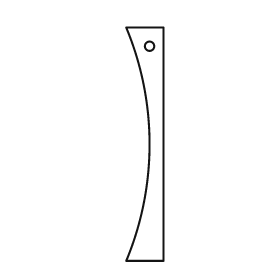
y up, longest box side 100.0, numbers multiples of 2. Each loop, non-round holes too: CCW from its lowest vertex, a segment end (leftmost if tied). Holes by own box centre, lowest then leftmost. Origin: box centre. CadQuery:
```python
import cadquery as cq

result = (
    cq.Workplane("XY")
    .moveTo(-8.0, -50.0)
    .lineTo(8.0, -50.0)
    .lineTo(8.0, 50.0)
    .lineTo(-8.0, 50.0)
    .threePointArc((2.0, 0.0), (-8.0, -50.0))
    .close()
    .moveTo(2.0, 42.0)
    .circle(2.0)
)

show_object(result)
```